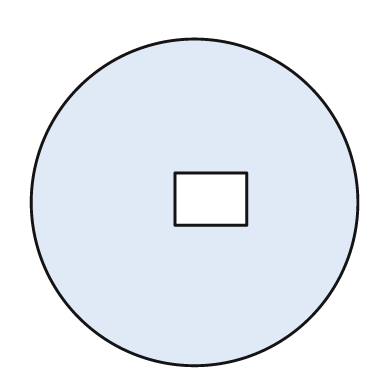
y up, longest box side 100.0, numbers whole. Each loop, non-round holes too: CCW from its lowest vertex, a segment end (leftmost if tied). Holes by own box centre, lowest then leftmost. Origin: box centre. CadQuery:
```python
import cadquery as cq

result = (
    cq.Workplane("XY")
    .moveTo(0.0, 0.0)
    .circle(50.0)
    .moveTo(-6.0, -7.0)
    .lineTo(16.0, -7.0)
    .lineTo(16.0, 9.0)
    .lineTo(-6.0, 9.0)
    .close()
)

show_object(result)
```